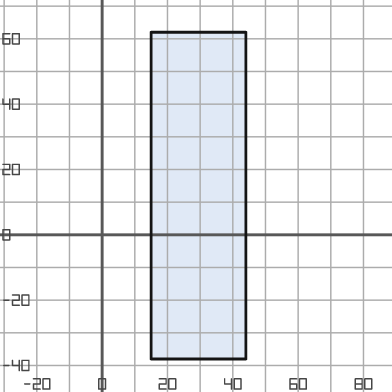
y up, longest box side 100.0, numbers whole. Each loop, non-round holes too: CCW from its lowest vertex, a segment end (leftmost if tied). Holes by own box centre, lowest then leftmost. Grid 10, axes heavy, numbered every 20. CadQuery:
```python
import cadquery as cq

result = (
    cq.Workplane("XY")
    .moveTo(15.0, -38.0)
    .lineTo(44.0, -38.0)
    .lineTo(44.0, 62.0)
    .lineTo(15.0, 62.0)
    .close()
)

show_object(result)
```